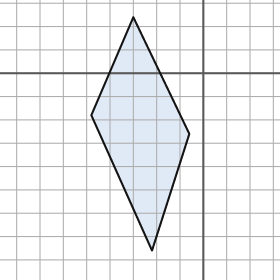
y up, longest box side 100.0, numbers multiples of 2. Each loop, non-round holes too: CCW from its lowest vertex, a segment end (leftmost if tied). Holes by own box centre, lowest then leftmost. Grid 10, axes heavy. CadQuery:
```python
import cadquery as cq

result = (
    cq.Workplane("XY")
    .moveTo(-22.0, -76.0)
    .lineTo(-6.0, -26.0)
    .lineTo(-30.0, 24.0)
    .lineTo(-48.0, -18.0)
    .close()
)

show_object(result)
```